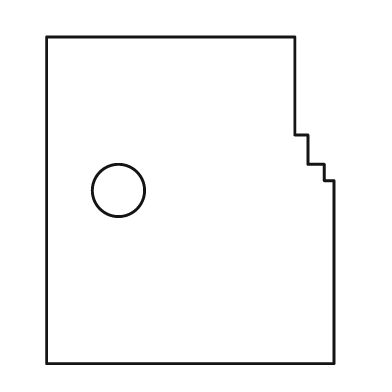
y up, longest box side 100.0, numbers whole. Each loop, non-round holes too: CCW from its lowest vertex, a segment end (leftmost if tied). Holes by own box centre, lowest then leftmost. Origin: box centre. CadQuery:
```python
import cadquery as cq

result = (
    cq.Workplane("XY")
    .moveTo(-44.0, -50.0)
    .lineTo(44.0, -50.0)
    .lineTo(44.0, 6.0)
    .lineTo(41.0, 6.0)
    .lineTo(41.0, 11.0)
    .lineTo(36.0, 11.0)
    .lineTo(36.0, 20.0)
    .lineTo(32.0, 20.0)
    .lineTo(32.0, 50.0)
    .lineTo(-44.0, 50.0)
    .close()
    .moveTo(-22.0, 3.0)
    .circle(8.0)
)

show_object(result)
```